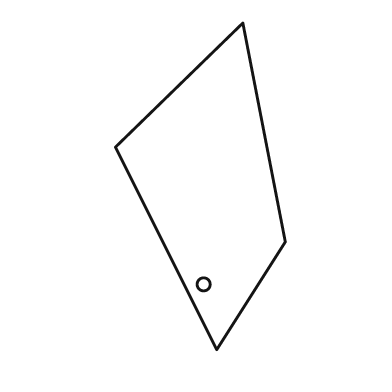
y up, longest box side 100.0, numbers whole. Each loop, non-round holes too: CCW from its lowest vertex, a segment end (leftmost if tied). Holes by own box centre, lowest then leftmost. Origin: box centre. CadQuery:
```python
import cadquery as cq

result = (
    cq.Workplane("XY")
    .moveTo(5.0, -50.0)
    .lineTo(26.0, -17.0)
    .lineTo(13.0, 50.0)
    .lineTo(-26.0, 12.0)
    .close()
    .moveTo(1.0, -30.0)
    .circle(2.0)
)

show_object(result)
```